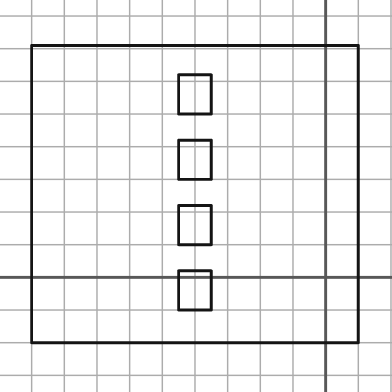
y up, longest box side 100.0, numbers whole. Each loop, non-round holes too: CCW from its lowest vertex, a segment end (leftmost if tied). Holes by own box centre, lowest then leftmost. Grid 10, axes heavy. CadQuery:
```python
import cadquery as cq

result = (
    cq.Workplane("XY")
    .moveTo(-90.0, -20.0)
    .lineTo(10.0, -20.0)
    .lineTo(10.0, 71.0)
    .lineTo(-90.0, 71.0)
    .close()
    .moveTo(-45.0, -10.0)
    .lineTo(-35.0, -10.0)
    .lineTo(-35.0, 2.0)
    .lineTo(-45.0, 2.0)
    .close()
    .moveTo(-45.0, 10.0)
    .lineTo(-35.0, 10.0)
    .lineTo(-35.0, 22.0)
    .lineTo(-45.0, 22.0)
    .close()
    .moveTo(-45.0, 30.0)
    .lineTo(-35.0, 30.0)
    .lineTo(-35.0, 42.0)
    .lineTo(-45.0, 42.0)
    .close()
    .moveTo(-45.0, 50.0)
    .lineTo(-35.0, 50.0)
    .lineTo(-35.0, 62.0)
    .lineTo(-45.0, 62.0)
    .close()
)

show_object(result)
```